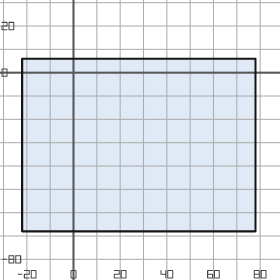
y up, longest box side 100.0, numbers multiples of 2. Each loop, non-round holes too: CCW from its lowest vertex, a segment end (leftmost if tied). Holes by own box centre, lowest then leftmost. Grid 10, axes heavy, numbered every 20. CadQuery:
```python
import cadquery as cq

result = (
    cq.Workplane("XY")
    .moveTo(-22.0, -68.0)
    .lineTo(78.0, -68.0)
    .lineTo(78.0, 6.0)
    .lineTo(-22.0, 6.0)
    .close()
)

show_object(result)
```